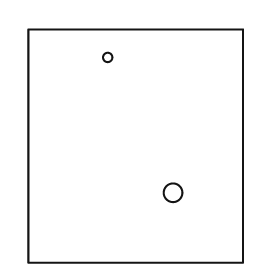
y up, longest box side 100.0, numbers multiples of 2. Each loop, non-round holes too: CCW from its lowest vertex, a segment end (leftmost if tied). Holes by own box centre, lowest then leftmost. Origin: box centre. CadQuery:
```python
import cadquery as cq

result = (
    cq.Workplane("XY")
    .moveTo(-46.0, -50.0)
    .lineTo(46.0, -50.0)
    .lineTo(46.0, 50.0)
    .lineTo(-46.0, 50.0)
    .close()
    .moveTo(16.0, -20.0)
    .circle(4.0)
    .moveTo(-12.0, 38.0)
    .circle(2.0)
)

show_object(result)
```